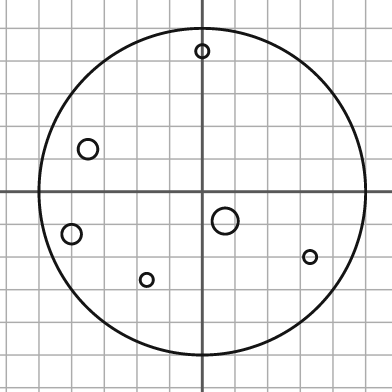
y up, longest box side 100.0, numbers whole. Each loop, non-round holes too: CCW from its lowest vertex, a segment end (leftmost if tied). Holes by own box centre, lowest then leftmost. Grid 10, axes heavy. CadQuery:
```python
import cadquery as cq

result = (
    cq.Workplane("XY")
    .moveTo(0.0, 0.0)
    .circle(50.0)
    .moveTo(-17.0, -27.0)
    .circle(2.0)
    .moveTo(33.0, -20.0)
    .circle(2.0)
    .moveTo(-40.0, -13.0)
    .circle(3.0)
    .moveTo(7.0, -9.0)
    .circle(4.0)
    .moveTo(-35.0, 13.0)
    .circle(3.0)
    .moveTo(0.0, 43.0)
    .circle(2.0)
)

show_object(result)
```